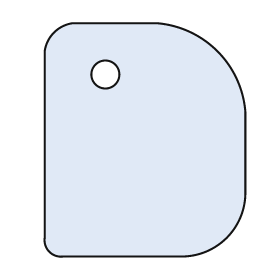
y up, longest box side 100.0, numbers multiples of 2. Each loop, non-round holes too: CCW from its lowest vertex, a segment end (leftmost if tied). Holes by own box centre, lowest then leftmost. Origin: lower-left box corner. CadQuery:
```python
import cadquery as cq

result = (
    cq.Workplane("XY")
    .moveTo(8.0, 0.0)
    .lineTo(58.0, 0.0)
    .threePointArc((78.0, 8.0), (86.0, 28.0))
    .lineTo(86.0, 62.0)
    .threePointArc((74.0, 88.0), (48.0, 100.0))
    .lineTo(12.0, 100.0)
    .threePointArc((4.0, 96.0), (0.0, 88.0))
    .lineTo(0.0, 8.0)
    .threePointArc((2.0, 2.0), (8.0, 0.0))
    .close()
    .moveTo(26.0, 78.0)
    .circle(6.0)
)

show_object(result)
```